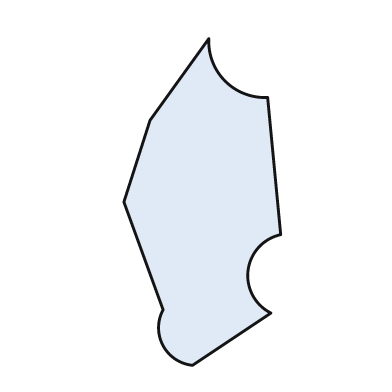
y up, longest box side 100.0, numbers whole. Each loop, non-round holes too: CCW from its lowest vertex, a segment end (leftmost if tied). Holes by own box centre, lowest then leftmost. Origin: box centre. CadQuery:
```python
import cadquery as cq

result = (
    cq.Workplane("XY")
    .moveTo(-3.0, -50.0)
    .lineTo(21.0, -34.0)
    .threePointArc((14.0, -21.0), (24.0, -10.0))
    .lineTo(20.0, 32.0)
    .threePointArc((7.0, 37.0), (2.0, 50.0))
    .lineTo(-16.0, 25.0)
    .lineTo(-24.0, 0.0)
    .lineTo(-12.0, -33.0)
    .threePointArc((-12.0, -44.0), (-3.0, -50.0))
    .close()
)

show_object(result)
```